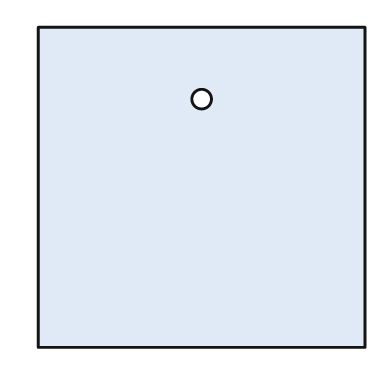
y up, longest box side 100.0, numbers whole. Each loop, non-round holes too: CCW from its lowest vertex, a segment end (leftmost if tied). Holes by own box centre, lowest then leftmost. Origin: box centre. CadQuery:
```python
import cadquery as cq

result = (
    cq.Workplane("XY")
    .moveTo(-50.0, -49.0)
    .lineTo(50.0, -49.0)
    .lineTo(50.0, 49.0)
    .lineTo(-50.0, 49.0)
    .close()
    .moveTo(0.0, 27.0)
    .circle(3.0)
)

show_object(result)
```